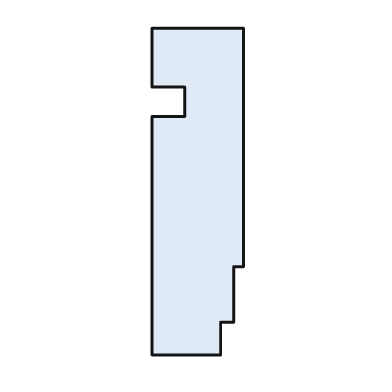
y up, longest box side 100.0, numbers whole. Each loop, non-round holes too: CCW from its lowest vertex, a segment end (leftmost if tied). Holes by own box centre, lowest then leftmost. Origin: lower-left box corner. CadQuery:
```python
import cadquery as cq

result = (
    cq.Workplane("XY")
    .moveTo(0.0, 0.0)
    .lineTo(21.0, 0.0)
    .lineTo(21.0, 10.0)
    .lineTo(25.0, 10.0)
    .lineTo(25.0, 27.0)
    .lineTo(28.0, 27.0)
    .lineTo(28.0, 100.0)
    .lineTo(0.0, 100.0)
    .lineTo(0.0, 82.0)
    .lineTo(10.0, 82.0)
    .lineTo(10.0, 73.0)
    .lineTo(0.0, 73.0)
    .close()
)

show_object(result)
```